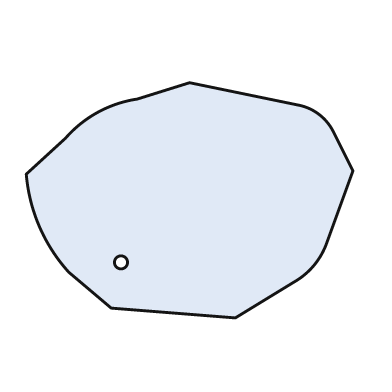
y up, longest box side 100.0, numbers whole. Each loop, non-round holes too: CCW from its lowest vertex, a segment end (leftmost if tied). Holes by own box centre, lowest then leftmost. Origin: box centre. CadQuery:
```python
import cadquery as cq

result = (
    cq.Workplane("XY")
    .moveTo(14.0, -36.0)
    .lineTo(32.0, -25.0)
    .threePointArc((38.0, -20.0), (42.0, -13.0))
    .lineTo(50.0, 9.0)
    .lineTo(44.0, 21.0)
    .threePointArc((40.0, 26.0), (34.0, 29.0))
    .lineTo(0.0, 36.0)
    .lineTo(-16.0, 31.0)
    .threePointArc((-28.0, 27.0), (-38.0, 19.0))
    .lineTo(-50.0, 8.0)
    .threePointArc((-46.0, -8.0), (-37.0, -22.0))
    .lineTo(-24.0, -33.0)
    .close()
    .moveTo(-21.0, -19.0)
    .circle(2.0)
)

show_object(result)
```